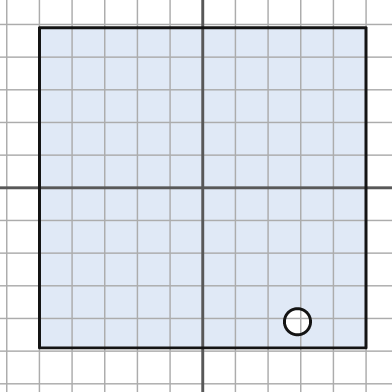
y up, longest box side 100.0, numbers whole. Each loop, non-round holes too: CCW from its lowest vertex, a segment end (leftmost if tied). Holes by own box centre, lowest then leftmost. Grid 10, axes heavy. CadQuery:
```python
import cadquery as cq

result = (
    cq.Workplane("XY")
    .moveTo(-50.0, -49.0)
    .lineTo(50.0, -49.0)
    .lineTo(50.0, 49.0)
    .lineTo(-50.0, 49.0)
    .close()
    .moveTo(29.0, -41.0)
    .circle(4.0)
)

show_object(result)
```